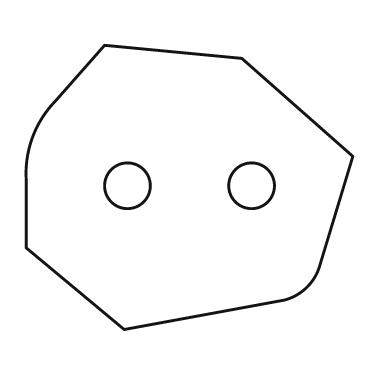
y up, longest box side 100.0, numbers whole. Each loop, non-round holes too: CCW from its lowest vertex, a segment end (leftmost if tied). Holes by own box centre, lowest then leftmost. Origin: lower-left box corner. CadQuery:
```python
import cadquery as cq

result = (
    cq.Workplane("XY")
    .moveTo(30.0, 0.0)
    .lineTo(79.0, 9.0)
    .threePointArc((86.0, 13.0), (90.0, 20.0))
    .lineTo(100.0, 53.0)
    .lineTo(66.0, 83.0)
    .lineTo(24.0, 87.0)
    .lineTo(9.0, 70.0)
    .threePointArc((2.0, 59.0), (0.0, 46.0))
    .lineTo(0.0, 25.0)
    .close()
    .moveTo(31.0, 44.0)
    .circle(7.0)
    .moveTo(69.0, 44.0)
    .circle(7.0)
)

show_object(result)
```